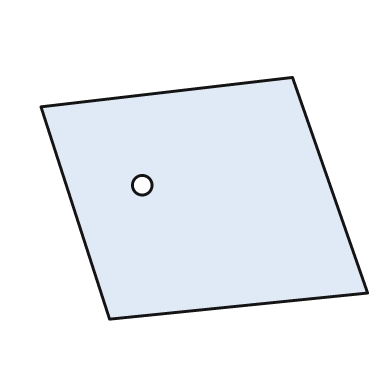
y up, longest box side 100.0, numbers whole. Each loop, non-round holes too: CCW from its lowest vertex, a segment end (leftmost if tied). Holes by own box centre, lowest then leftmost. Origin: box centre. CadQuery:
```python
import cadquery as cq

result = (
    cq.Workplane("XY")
    .moveTo(-29.0, -37.0)
    .lineTo(50.0, -29.0)
    .lineTo(27.0, 37.0)
    .lineTo(-50.0, 28.0)
    .close()
    .moveTo(-19.0, 4.0)
    .circle(3.0)
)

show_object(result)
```